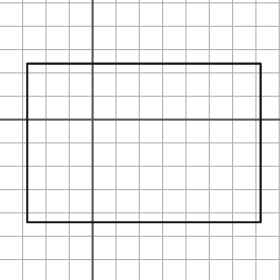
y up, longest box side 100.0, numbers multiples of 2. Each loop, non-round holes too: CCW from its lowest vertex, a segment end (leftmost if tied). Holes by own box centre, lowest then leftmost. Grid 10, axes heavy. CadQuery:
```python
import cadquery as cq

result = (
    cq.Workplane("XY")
    .moveTo(-28.0, -44.0)
    .lineTo(72.0, -44.0)
    .lineTo(72.0, 24.0)
    .lineTo(-28.0, 24.0)
    .close()
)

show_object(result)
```